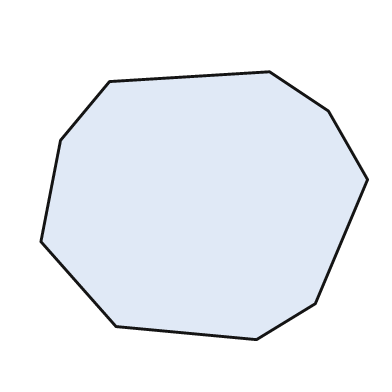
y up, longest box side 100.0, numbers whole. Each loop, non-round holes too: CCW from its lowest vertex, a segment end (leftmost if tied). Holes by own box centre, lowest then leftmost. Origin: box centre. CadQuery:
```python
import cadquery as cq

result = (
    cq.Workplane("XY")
    .moveTo(16.0, -41.0)
    .lineTo(34.0, -30.0)
    .lineTo(50.0, 8.0)
    .lineTo(38.0, 29.0)
    .lineTo(20.0, 41.0)
    .lineTo(-29.0, 38.0)
    .lineTo(-44.0, 20.0)
    .lineTo(-50.0, -11.0)
    .lineTo(-27.0, -37.0)
    .close()
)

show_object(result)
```